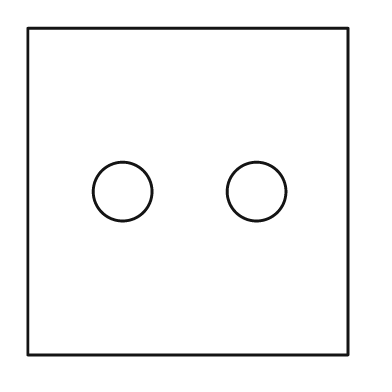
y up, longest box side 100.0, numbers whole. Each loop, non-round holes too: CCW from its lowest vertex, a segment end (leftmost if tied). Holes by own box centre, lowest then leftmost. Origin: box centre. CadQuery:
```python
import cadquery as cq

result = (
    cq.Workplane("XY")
    .moveTo(-49.0, -50.0)
    .lineTo(49.0, -50.0)
    .lineTo(49.0, 50.0)
    .lineTo(-49.0, 50.0)
    .close()
    .moveTo(-20.0, 0.0)
    .circle(9.0)
    .moveTo(21.0, 0.0)
    .circle(9.0)
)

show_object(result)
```